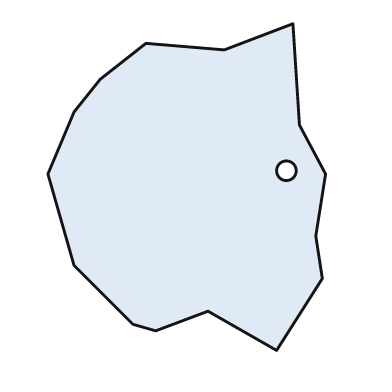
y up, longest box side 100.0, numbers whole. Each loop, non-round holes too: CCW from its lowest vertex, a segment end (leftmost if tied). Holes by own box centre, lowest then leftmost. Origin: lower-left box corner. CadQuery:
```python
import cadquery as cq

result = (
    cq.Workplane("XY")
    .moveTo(70.0, 0.0)
    .lineTo(84.0, 22.0)
    .lineTo(82.0, 35.0)
    .lineTo(85.0, 54.0)
    .lineTo(77.0, 69.0)
    .lineTo(75.0, 100.0)
    .lineTo(54.0, 92.0)
    .lineTo(30.0, 94.0)
    .lineTo(16.0, 83.0)
    .lineTo(8.0, 73.0)
    .lineTo(0.0, 54.0)
    .lineTo(8.0, 26.0)
    .lineTo(26.0, 8.0)
    .lineTo(33.0, 6.0)
    .lineTo(49.0, 12.0)
    .close()
    .moveTo(73.0, 55.0)
    .circle(3.0)
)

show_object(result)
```